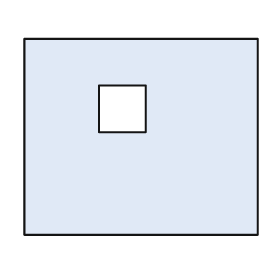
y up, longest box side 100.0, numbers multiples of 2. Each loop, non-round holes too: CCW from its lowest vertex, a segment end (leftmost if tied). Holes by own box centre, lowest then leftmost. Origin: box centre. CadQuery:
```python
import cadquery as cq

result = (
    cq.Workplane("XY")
    .moveTo(-50.0, -42.0)
    .lineTo(50.0, -42.0)
    .lineTo(50.0, 42.0)
    .lineTo(-50.0, 42.0)
    .close()
    .moveTo(-18.0, 2.0)
    .lineTo(2.0, 2.0)
    .lineTo(2.0, 22.0)
    .lineTo(-18.0, 22.0)
    .close()
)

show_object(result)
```